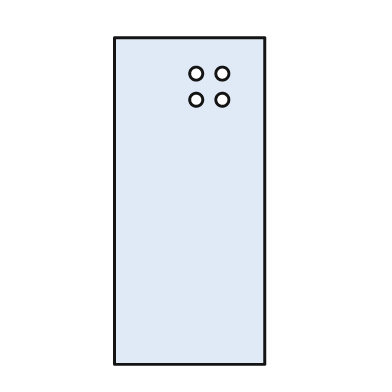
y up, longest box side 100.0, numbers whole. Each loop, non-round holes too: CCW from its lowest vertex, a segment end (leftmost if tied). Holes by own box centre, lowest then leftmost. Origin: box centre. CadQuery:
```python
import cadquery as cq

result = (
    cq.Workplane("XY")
    .moveTo(-23.0, -50.0)
    .lineTo(23.0, -50.0)
    .lineTo(23.0, 50.0)
    .lineTo(-23.0, 50.0)
    .close()
    .moveTo(2.0, 31.0)
    .circle(2.0)
    .moveTo(10.0, 31.0)
    .circle(2.0)
    .moveTo(2.0, 39.0)
    .circle(2.0)
    .moveTo(10.0, 39.0)
    .circle(2.0)
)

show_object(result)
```